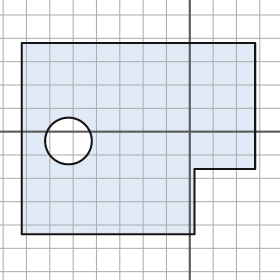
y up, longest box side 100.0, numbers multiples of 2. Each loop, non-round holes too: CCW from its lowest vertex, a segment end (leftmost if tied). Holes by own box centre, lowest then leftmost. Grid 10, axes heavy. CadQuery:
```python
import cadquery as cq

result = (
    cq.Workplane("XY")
    .moveTo(-72.0, -44.0)
    .lineTo(2.0, -44.0)
    .lineTo(2.0, -16.0)
    .lineTo(28.0, -16.0)
    .lineTo(28.0, 38.0)
    .lineTo(-72.0, 38.0)
    .close()
    .moveTo(-52.0, -4.0)
    .circle(10.0)
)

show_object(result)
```